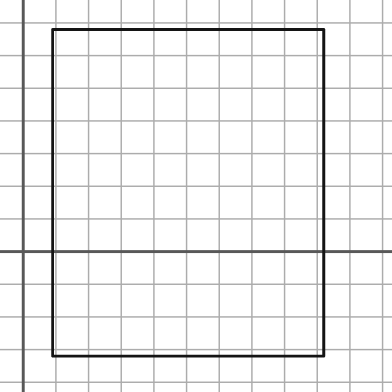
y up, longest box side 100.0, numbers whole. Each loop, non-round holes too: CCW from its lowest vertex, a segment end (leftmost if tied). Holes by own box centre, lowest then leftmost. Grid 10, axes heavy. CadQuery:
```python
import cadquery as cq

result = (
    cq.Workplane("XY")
    .moveTo(9.0, -32.0)
    .lineTo(92.0, -32.0)
    .lineTo(92.0, 68.0)
    .lineTo(9.0, 68.0)
    .close()
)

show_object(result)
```